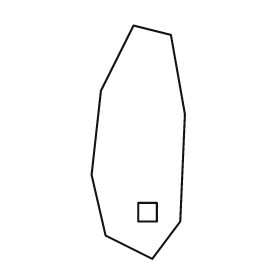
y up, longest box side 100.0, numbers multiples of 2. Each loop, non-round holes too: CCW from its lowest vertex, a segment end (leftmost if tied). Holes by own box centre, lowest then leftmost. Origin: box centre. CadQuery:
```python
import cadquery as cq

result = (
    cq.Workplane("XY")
    .moveTo(6.0, -50.0)
    .lineTo(18.0, -34.0)
    .lineTo(20.0, 12.0)
    .lineTo(14.0, 46.0)
    .lineTo(-2.0, 50.0)
    .lineTo(-16.0, 22.0)
    .lineTo(-20.0, -14.0)
    .lineTo(-14.0, -40.0)
    .close()
    .moveTo(0.0, -34.0)
    .lineTo(8.0, -34.0)
    .lineTo(8.0, -26.0)
    .lineTo(0.0, -26.0)
    .close()
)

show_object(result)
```